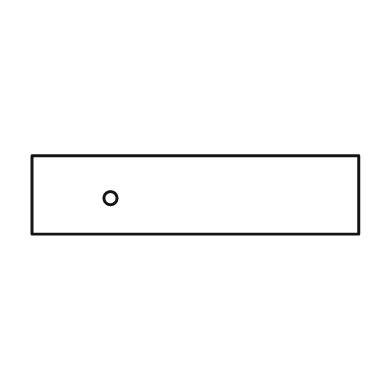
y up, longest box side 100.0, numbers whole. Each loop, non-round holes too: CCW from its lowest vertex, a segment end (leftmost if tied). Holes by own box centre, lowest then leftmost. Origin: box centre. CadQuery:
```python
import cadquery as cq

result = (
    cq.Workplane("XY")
    .moveTo(-50.0, -12.0)
    .lineTo(50.0, -12.0)
    .lineTo(50.0, 12.0)
    .lineTo(-50.0, 12.0)
    .close()
    .moveTo(-26.0, -1.0)
    .circle(2.0)
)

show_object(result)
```